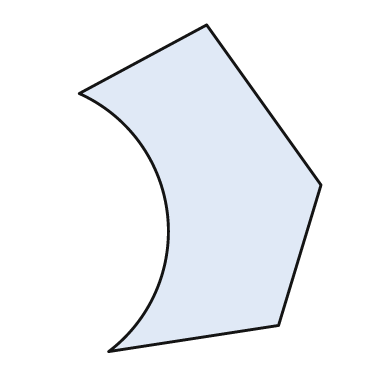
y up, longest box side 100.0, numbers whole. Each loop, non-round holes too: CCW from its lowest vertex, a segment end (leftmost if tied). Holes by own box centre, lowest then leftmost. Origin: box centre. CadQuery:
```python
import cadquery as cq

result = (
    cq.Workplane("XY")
    .moveTo(-28.0, -50.0)
    .lineTo(24.0, -42.0)
    .lineTo(37.0, 1.0)
    .lineTo(2.0, 50.0)
    .lineTo(-37.0, 29.0)
    .threePointArc((-10.0, -8.0), (-28.0, -50.0))
    .close()
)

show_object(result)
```